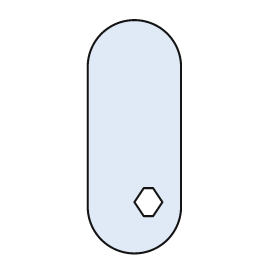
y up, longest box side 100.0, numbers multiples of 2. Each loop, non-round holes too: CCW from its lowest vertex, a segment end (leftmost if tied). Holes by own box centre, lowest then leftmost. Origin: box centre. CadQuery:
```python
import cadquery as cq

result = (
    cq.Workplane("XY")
    .moveTo(-20.0, -30.0)
    .threePointArc((0.0, -50.0), (20.0, -30.0))
    .lineTo(20.0, 30.0)
    .threePointArc((0.0, 50.0), (-20.0, 30.0))
    .close()
    .moveTo(4.0, -34.0)
    .lineTo(8.0, -34.0)
    .lineTo(12.0, -28.0)
    .lineTo(8.0, -22.0)
    .lineTo(4.0, -22.0)
    .lineTo(0.0, -28.0)
    .close()
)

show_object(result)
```